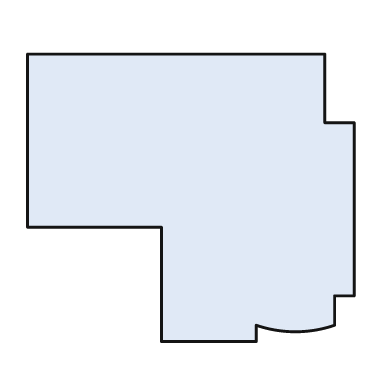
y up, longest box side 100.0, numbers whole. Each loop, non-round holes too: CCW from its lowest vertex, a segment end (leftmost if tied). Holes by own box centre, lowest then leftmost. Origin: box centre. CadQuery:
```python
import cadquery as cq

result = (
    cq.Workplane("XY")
    .moveTo(-9.0, -44.0)
    .lineTo(20.0, -44.0)
    .lineTo(20.0, -39.0)
    .threePointArc((32.0, -41.0), (44.0, -39.0))
    .lineTo(44.0, -30.0)
    .lineTo(50.0, -30.0)
    .lineTo(50.0, 23.0)
    .lineTo(41.0, 23.0)
    .lineTo(41.0, 44.0)
    .lineTo(-50.0, 44.0)
    .lineTo(-50.0, -9.0)
    .lineTo(-9.0, -9.0)
    .close()
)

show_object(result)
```